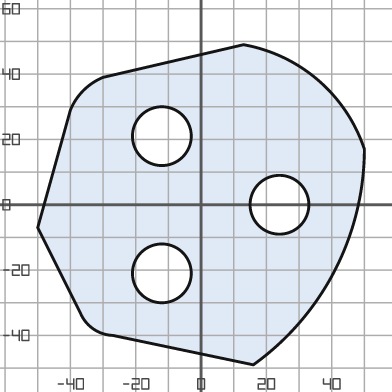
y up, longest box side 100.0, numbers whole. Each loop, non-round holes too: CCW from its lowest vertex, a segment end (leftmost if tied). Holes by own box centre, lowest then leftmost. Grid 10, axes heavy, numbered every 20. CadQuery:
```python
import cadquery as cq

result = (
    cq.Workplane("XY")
    .moveTo(16.0, -49.0)
    .threePointArc((41.0, -20.0), (50.0, 17.0))
    .threePointArc((36.0, 38.0), (13.0, 49.0))
    .lineTo(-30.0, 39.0)
    .threePointArc((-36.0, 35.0), (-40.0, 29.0))
    .lineTo(-50.0, -7.0)
    .lineTo(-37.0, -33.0)
    .threePointArc((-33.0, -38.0), (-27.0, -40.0))
    .close()
    .moveTo(-12.0, -21.0)
    .circle(9.0)
    .moveTo(24.0, 0.0)
    .circle(9.0)
    .moveTo(-12.0, 21.0)
    .circle(9.0)
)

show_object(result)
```